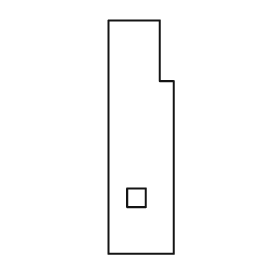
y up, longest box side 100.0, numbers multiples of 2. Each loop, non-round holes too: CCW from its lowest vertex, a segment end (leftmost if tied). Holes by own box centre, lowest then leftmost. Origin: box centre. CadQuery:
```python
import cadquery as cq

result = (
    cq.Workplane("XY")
    .moveTo(-14.0, -50.0)
    .lineTo(14.0, -50.0)
    .lineTo(14.0, 24.0)
    .lineTo(8.0, 24.0)
    .lineTo(8.0, 50.0)
    .lineTo(-14.0, 50.0)
    .close()
    .moveTo(-6.0, -30.0)
    .lineTo(2.0, -30.0)
    .lineTo(2.0, -22.0)
    .lineTo(-6.0, -22.0)
    .close()
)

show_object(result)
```